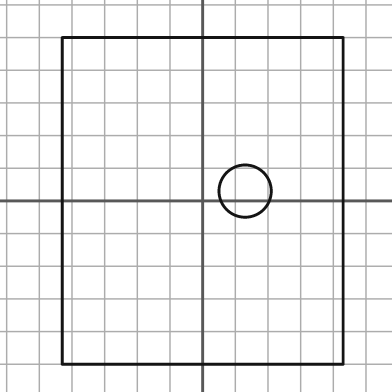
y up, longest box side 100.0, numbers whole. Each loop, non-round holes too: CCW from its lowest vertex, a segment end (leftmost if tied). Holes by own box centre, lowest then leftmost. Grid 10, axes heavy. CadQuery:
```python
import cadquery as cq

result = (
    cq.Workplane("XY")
    .moveTo(-43.0, -50.0)
    .lineTo(43.0, -50.0)
    .lineTo(43.0, 50.0)
    .lineTo(-43.0, 50.0)
    .close()
    .moveTo(13.0, 3.0)
    .circle(8.0)
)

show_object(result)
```